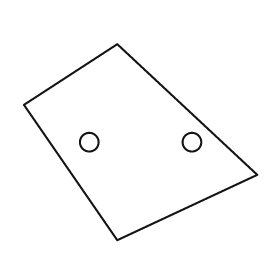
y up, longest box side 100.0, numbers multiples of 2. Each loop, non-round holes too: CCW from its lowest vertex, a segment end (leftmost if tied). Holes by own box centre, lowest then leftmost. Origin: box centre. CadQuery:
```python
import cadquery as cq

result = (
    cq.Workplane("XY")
    .moveTo(-10.0, -42.0)
    .lineTo(50.0, -14.0)
    .lineTo(-10.0, 42.0)
    .lineTo(-50.0, 16.0)
    .close()
    .moveTo(-22.0, 0.0)
    .circle(4.0)
    .moveTo(22.0, 0.0)
    .circle(4.0)
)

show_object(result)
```